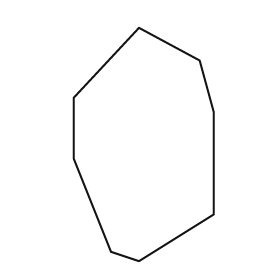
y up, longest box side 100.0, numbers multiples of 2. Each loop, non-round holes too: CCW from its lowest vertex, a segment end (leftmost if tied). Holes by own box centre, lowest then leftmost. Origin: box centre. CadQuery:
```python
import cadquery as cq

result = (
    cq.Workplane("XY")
    .moveTo(-2.0, -50.0)
    .lineTo(30.0, -30.0)
    .lineTo(30.0, 14.0)
    .lineTo(24.0, 36.0)
    .lineTo(-2.0, 50.0)
    .lineTo(-30.0, 20.0)
    .lineTo(-30.0, -6.0)
    .lineTo(-14.0, -46.0)
    .close()
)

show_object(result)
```